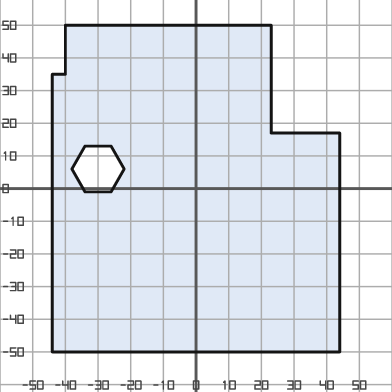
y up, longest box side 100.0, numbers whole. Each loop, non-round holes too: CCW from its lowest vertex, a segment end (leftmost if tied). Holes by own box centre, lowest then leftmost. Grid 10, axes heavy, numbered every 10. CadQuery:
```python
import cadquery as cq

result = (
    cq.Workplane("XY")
    .moveTo(-44.0, -50.0)
    .lineTo(44.0, -50.0)
    .lineTo(44.0, 17.0)
    .lineTo(23.0, 17.0)
    .lineTo(23.0, 50.0)
    .lineTo(-40.0, 50.0)
    .lineTo(-40.0, 35.0)
    .lineTo(-44.0, 35.0)
    .close()
    .moveTo(-34.0, -1.0)
    .lineTo(-26.0, -1.0)
    .lineTo(-22.0, 6.0)
    .lineTo(-26.0, 13.0)
    .lineTo(-34.0, 13.0)
    .lineTo(-38.0, 6.0)
    .close()
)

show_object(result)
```